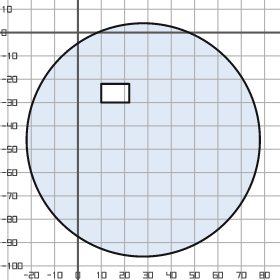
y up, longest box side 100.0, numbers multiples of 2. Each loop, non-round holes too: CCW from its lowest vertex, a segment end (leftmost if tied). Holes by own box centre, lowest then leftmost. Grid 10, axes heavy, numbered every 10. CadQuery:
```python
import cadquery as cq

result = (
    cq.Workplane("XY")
    .moveTo(28.0, -46.0)
    .circle(50.0)
    .moveTo(10.0, -30.0)
    .lineTo(22.0, -30.0)
    .lineTo(22.0, -22.0)
    .lineTo(10.0, -22.0)
    .close()
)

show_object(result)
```